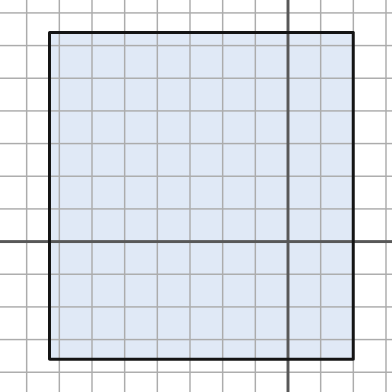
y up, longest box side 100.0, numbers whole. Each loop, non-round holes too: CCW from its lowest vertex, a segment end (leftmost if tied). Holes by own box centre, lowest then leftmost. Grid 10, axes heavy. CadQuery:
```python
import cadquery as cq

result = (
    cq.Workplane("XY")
    .moveTo(-73.0, -36.0)
    .lineTo(20.0, -36.0)
    .lineTo(20.0, 64.0)
    .lineTo(-73.0, 64.0)
    .close()
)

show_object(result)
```